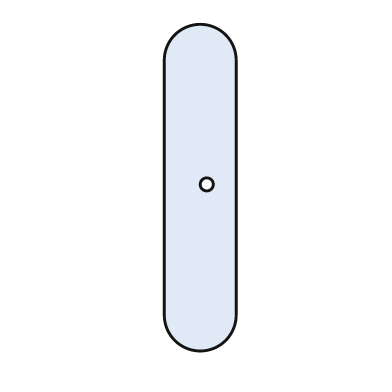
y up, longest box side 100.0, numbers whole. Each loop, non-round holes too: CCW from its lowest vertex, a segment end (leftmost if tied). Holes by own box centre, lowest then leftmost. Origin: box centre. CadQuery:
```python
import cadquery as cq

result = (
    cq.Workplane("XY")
    .moveTo(-11.0, -39.0)
    .threePointArc((0.0, -50.0), (11.0, -39.0))
    .lineTo(11.0, 39.0)
    .threePointArc((0.0, 50.0), (-11.0, 39.0))
    .close()
    .moveTo(2.0, 1.0)
    .circle(2.0)
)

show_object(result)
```